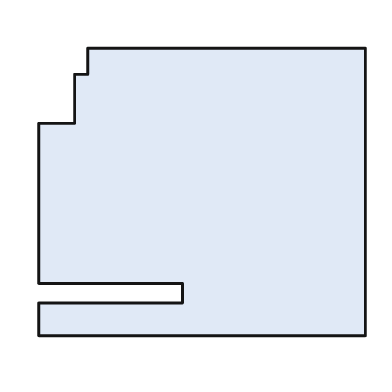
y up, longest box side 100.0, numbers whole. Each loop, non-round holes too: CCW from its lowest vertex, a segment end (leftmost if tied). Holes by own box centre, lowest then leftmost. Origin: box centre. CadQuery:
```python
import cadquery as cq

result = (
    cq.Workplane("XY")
    .moveTo(-50.0, -44.0)
    .lineTo(50.0, -44.0)
    .lineTo(50.0, 44.0)
    .lineTo(-35.0, 44.0)
    .lineTo(-35.0, 36.0)
    .lineTo(-39.0, 36.0)
    .lineTo(-39.0, 21.0)
    .lineTo(-50.0, 21.0)
    .lineTo(-50.0, -28.0)
    .lineTo(-6.0, -28.0)
    .lineTo(-6.0, -34.0)
    .lineTo(-50.0, -34.0)
    .close()
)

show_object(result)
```